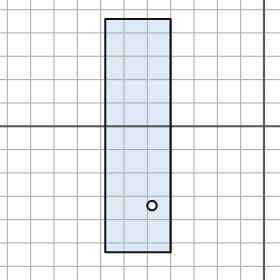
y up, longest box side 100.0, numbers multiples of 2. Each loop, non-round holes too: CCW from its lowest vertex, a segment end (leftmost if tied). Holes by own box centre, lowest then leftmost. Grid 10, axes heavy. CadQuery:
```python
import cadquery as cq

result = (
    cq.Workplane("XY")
    .moveTo(-68.0, -54.0)
    .lineTo(-40.0, -54.0)
    .lineTo(-40.0, 46.0)
    .lineTo(-68.0, 46.0)
    .close()
    .moveTo(-48.0, -34.0)
    .circle(2.0)
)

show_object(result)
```